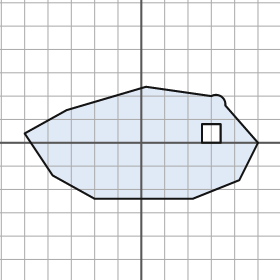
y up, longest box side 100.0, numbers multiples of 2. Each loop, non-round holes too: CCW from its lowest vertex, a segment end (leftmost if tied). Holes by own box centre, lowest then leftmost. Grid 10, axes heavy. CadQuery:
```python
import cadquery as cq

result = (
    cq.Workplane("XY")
    .moveTo(-20.0, -24.0)
    .lineTo(22.0, -24.0)
    .lineTo(42.0, -16.0)
    .lineTo(50.0, 0.0)
    .lineTo(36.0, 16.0)
    .threePointArc((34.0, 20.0), (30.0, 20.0))
    .lineTo(2.0, 24.0)
    .lineTo(-32.0, 14.0)
    .lineTo(-50.0, 4.0)
    .lineTo(-38.0, -14.0)
    .close()
    .moveTo(26.0, 0.0)
    .lineTo(34.0, 0.0)
    .lineTo(34.0, 8.0)
    .lineTo(26.0, 8.0)
    .close()
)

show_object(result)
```